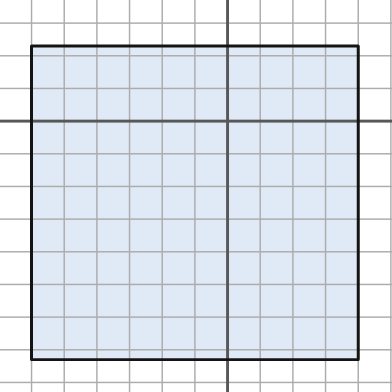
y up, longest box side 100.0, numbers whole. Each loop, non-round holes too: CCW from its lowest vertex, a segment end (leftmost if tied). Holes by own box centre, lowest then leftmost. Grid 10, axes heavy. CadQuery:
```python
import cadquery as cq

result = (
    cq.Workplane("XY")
    .moveTo(-60.0, -73.0)
    .lineTo(40.0, -73.0)
    .lineTo(40.0, 23.0)
    .lineTo(-60.0, 23.0)
    .close()
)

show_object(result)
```